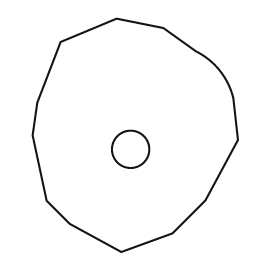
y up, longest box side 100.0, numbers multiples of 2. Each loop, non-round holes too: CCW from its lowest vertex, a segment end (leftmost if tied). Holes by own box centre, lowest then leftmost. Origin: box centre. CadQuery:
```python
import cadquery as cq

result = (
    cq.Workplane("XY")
    .moveTo(-6.0, -50.0)
    .lineTo(16.0, -42.0)
    .lineTo(30.0, -28.0)
    .lineTo(44.0, -2.0)
    .lineTo(42.0, 16.0)
    .threePointArc((36.0, 28.0), (26.0, 36.0))
    .lineTo(12.0, 46.0)
    .lineTo(-8.0, 50.0)
    .lineTo(-32.0, 40.0)
    .lineTo(-42.0, 14.0)
    .lineTo(-44.0, 0.0)
    .lineTo(-38.0, -28.0)
    .lineTo(-28.0, -38.0)
    .close()
    .moveTo(-2.0, -6.0)
    .circle(8.0)
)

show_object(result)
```